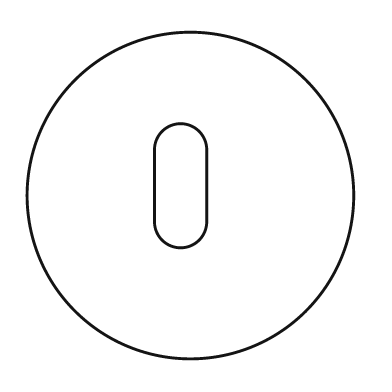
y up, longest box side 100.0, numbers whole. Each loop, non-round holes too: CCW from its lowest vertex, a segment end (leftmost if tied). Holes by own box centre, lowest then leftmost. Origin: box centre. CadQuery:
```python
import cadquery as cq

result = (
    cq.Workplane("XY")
    .moveTo(0.0, 0.0)
    .circle(50.0)
    .moveTo(-11.0, -8.0)
    .threePointArc((-3.0, -16.0), (5.0, -8.0))
    .lineTo(5.0, 14.0)
    .threePointArc((-3.0, 22.0), (-11.0, 14.0))
    .close()
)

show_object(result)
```